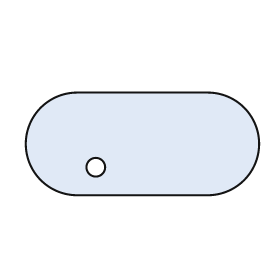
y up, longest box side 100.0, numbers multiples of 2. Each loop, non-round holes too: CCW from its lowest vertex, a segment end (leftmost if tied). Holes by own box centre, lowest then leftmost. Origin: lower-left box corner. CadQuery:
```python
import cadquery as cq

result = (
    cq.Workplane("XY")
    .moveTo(22.0, 0.0)
    .lineTo(78.0, 0.0)
    .threePointArc((100.0, 22.0), (78.0, 44.0))
    .lineTo(22.0, 44.0)
    .threePointArc((0.0, 22.0), (22.0, 0.0))
    .close()
    .moveTo(30.0, 12.0)
    .circle(4.0)
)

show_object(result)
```